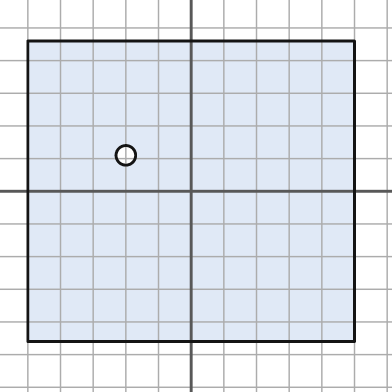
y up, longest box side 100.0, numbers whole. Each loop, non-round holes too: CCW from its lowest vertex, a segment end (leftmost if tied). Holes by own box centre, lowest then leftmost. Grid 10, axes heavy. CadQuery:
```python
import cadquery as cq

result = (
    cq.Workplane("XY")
    .moveTo(-50.0, -46.0)
    .lineTo(50.0, -46.0)
    .lineTo(50.0, 46.0)
    .lineTo(-50.0, 46.0)
    .close()
    .moveTo(-20.0, 11.0)
    .circle(3.0)
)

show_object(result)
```